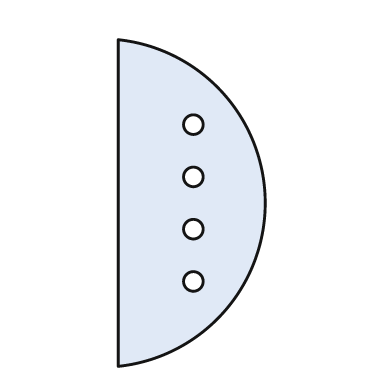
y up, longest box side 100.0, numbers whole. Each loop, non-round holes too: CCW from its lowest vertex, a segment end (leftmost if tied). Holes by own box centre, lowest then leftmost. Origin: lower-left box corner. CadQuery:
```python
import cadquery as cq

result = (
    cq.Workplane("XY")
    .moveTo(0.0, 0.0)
    .threePointArc((45.0, 50.0), (0.0, 100.0))
    .close()
    .moveTo(23.0, 26.0)
    .circle(3.0)
    .moveTo(23.0, 42.0)
    .circle(3.0)
    .moveTo(23.0, 58.0)
    .circle(3.0)
    .moveTo(23.0, 74.0)
    .circle(3.0)
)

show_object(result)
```